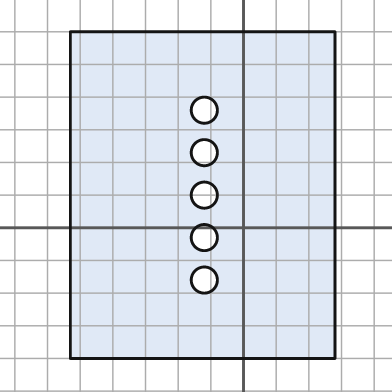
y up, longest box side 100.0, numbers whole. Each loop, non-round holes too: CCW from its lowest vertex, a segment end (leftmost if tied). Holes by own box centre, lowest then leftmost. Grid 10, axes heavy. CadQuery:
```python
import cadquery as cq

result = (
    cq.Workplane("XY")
    .moveTo(-53.0, -40.0)
    .lineTo(28.0, -40.0)
    .lineTo(28.0, 60.0)
    .lineTo(-53.0, 60.0)
    .close()
    .moveTo(-12.0, -16.0)
    .circle(4.0)
    .moveTo(-12.0, -3.0)
    .circle(4.0)
    .moveTo(-12.0, 10.0)
    .circle(4.0)
    .moveTo(-12.0, 23.0)
    .circle(4.0)
    .moveTo(-12.0, 36.0)
    .circle(4.0)
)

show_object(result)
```